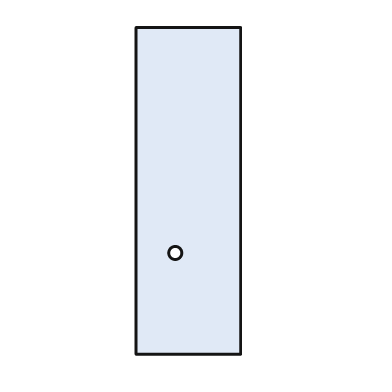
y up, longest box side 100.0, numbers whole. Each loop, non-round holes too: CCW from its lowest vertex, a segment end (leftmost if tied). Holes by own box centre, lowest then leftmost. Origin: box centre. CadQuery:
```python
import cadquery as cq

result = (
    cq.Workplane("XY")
    .moveTo(-16.0, -50.0)
    .lineTo(16.0, -50.0)
    .lineTo(16.0, 50.0)
    .lineTo(-16.0, 50.0)
    .close()
    .moveTo(-4.0, -19.0)
    .circle(2.0)
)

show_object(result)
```